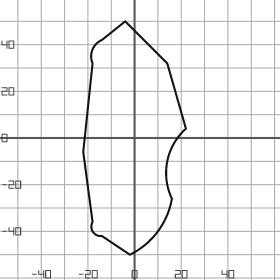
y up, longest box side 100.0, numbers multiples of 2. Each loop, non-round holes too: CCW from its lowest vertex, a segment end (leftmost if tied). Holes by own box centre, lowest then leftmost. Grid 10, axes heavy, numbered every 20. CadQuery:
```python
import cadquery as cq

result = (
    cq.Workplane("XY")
    .moveTo(-2.0, -50.0)
    .threePointArc((10.0, -40.0), (16.0, -26.0))
    .threePointArc((14.0, -10.0), (22.0, 4.0))
    .lineTo(14.0, 32.0)
    .lineTo(-4.0, 50.0)
    .lineTo(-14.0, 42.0)
    .threePointArc((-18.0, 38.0), (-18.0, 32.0))
    .lineTo(-22.0, -6.0)
    .lineTo(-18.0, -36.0)
    .threePointArc((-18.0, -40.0), (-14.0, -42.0))
    .close()
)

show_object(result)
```